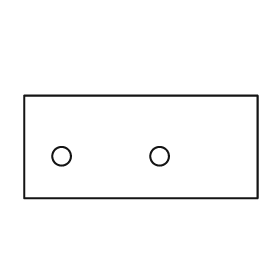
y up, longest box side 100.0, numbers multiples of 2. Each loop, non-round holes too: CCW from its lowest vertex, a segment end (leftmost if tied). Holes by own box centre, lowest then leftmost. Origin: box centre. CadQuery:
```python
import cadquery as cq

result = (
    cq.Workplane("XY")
    .moveTo(-50.0, -22.0)
    .lineTo(50.0, -22.0)
    .lineTo(50.0, 22.0)
    .lineTo(-50.0, 22.0)
    .close()
    .moveTo(-34.0, -4.0)
    .circle(4.0)
    .moveTo(8.0, -4.0)
    .circle(4.0)
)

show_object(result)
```